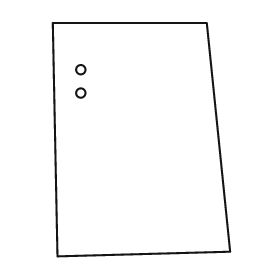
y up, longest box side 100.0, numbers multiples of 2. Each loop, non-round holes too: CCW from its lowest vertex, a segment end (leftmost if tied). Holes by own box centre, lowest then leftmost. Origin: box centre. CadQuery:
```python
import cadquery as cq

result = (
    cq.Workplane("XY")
    .moveTo(-36.0, -50.0)
    .lineTo(38.0, -48.0)
    .lineTo(28.0, 50.0)
    .lineTo(-38.0, 50.0)
    .close()
    .moveTo(-26.0, 20.0)
    .circle(2.0)
    .moveTo(-26.0, 30.0)
    .circle(2.0)
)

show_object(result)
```